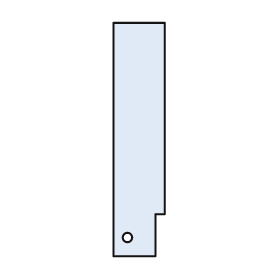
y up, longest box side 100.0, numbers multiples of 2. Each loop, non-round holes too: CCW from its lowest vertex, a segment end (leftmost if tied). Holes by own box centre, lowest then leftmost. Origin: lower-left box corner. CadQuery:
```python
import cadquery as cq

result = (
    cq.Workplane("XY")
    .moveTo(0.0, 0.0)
    .lineTo(18.0, 0.0)
    .lineTo(18.0, 18.0)
    .lineTo(22.0, 18.0)
    .lineTo(22.0, 100.0)
    .lineTo(0.0, 100.0)
    .close()
    .moveTo(6.0, 8.0)
    .circle(2.0)
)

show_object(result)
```